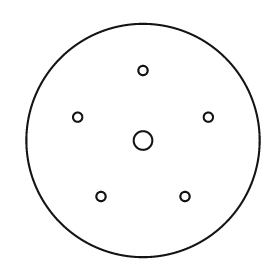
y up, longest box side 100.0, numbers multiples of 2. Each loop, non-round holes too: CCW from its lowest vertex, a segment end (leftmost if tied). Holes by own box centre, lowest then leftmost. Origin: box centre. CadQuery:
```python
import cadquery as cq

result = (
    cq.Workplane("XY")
    .moveTo(0.0, 0.0)
    .circle(50.0)
    .moveTo(-18.0, -24.0)
    .circle(2.0)
    .moveTo(18.0, -24.0)
    .circle(2.0)
    .moveTo(0.0, 0.0)
    .circle(4.0)
    .moveTo(-28.0, 10.0)
    .circle(2.0)
    .moveTo(28.0, 10.0)
    .circle(2.0)
    .moveTo(0.0, 30.0)
    .circle(2.0)
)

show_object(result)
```